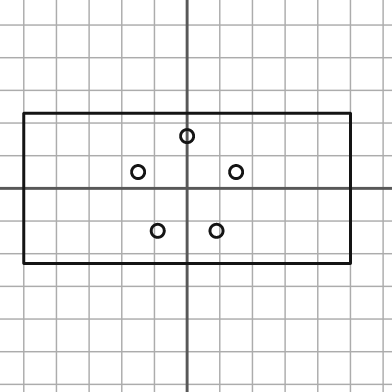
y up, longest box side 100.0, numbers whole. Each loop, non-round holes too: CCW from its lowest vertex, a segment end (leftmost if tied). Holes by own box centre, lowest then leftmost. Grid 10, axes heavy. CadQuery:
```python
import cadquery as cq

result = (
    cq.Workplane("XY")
    .moveTo(-50.0, -23.0)
    .lineTo(50.0, -23.0)
    .lineTo(50.0, 23.0)
    .lineTo(-50.0, 23.0)
    .close()
    .moveTo(-9.0, -13.0)
    .circle(2.0)
    .moveTo(9.0, -13.0)
    .circle(2.0)
    .moveTo(-15.0, 5.0)
    .circle(2.0)
    .moveTo(15.0, 5.0)
    .circle(2.0)
    .moveTo(0.0, 16.0)
    .circle(2.0)
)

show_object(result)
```